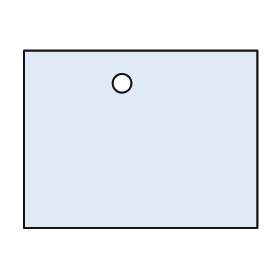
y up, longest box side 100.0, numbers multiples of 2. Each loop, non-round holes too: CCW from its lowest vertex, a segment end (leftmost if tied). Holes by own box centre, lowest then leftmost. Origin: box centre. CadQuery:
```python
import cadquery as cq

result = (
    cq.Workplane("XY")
    .moveTo(-50.0, -38.0)
    .lineTo(50.0, -38.0)
    .lineTo(50.0, 38.0)
    .lineTo(-50.0, 38.0)
    .close()
    .moveTo(-8.0, 24.0)
    .circle(4.0)
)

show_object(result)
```